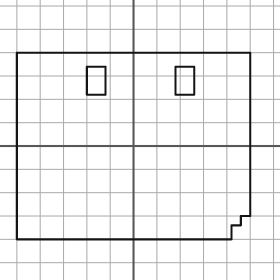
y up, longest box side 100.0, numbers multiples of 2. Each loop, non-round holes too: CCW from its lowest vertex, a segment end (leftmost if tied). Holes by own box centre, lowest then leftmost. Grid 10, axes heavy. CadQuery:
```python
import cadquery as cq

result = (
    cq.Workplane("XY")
    .moveTo(-50.0, -40.0)
    .lineTo(42.0, -40.0)
    .lineTo(42.0, -34.0)
    .lineTo(46.0, -34.0)
    .lineTo(46.0, -30.0)
    .lineTo(50.0, -30.0)
    .lineTo(50.0, 40.0)
    .lineTo(-50.0, 40.0)
    .close()
    .moveTo(-20.0, 22.0)
    .lineTo(-12.0, 22.0)
    .lineTo(-12.0, 34.0)
    .lineTo(-20.0, 34.0)
    .close()
    .moveTo(18.0, 22.0)
    .lineTo(26.0, 22.0)
    .lineTo(26.0, 34.0)
    .lineTo(18.0, 34.0)
    .close()
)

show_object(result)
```